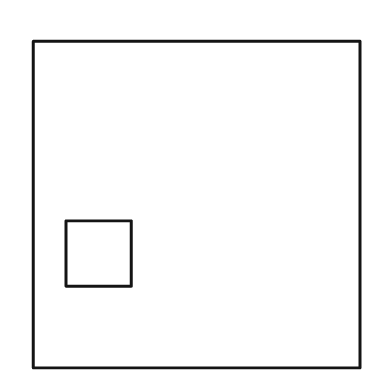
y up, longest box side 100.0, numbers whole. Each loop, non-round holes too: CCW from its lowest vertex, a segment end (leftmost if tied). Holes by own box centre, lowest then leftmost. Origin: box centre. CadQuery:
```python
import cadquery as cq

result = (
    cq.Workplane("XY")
    .moveTo(-50.0, -50.0)
    .lineTo(50.0, -50.0)
    .lineTo(50.0, 50.0)
    .lineTo(-50.0, 50.0)
    .close()
    .moveTo(-40.0, -25.0)
    .lineTo(-20.0, -25.0)
    .lineTo(-20.0, -5.0)
    .lineTo(-40.0, -5.0)
    .close()
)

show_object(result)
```